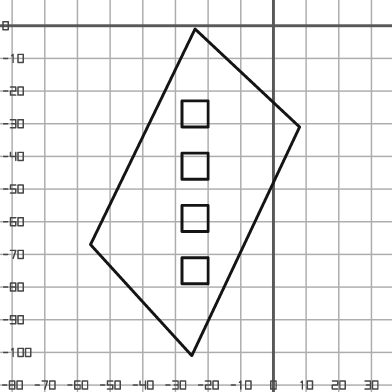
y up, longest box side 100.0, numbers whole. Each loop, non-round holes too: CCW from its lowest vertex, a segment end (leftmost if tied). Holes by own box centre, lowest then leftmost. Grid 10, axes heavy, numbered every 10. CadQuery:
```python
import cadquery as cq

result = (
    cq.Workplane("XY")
    .moveTo(-25.0, -101.0)
    .lineTo(8.0, -31.0)
    .lineTo(-24.0, -1.0)
    .lineTo(-56.0, -67.0)
    .close()
    .moveTo(-28.0, -79.0)
    .lineTo(-20.0, -79.0)
    .lineTo(-20.0, -71.0)
    .lineTo(-28.0, -71.0)
    .close()
    .moveTo(-28.0, -63.0)
    .lineTo(-20.0, -63.0)
    .lineTo(-20.0, -55.0)
    .lineTo(-28.0, -55.0)
    .close()
    .moveTo(-28.0, -47.0)
    .lineTo(-20.0, -47.0)
    .lineTo(-20.0, -39.0)
    .lineTo(-28.0, -39.0)
    .close()
    .moveTo(-28.0, -31.0)
    .lineTo(-20.0, -31.0)
    .lineTo(-20.0, -23.0)
    .lineTo(-28.0, -23.0)
    .close()
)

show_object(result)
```